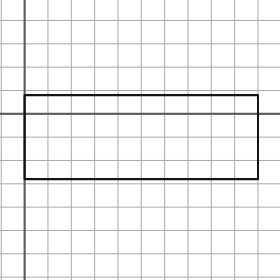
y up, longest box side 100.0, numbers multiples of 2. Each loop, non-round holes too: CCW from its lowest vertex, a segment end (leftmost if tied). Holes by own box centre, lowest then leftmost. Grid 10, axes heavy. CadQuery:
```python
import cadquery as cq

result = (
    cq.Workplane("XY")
    .moveTo(0.0, -28.0)
    .lineTo(100.0, -28.0)
    .lineTo(100.0, 8.0)
    .lineTo(0.0, 8.0)
    .close()
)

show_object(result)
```